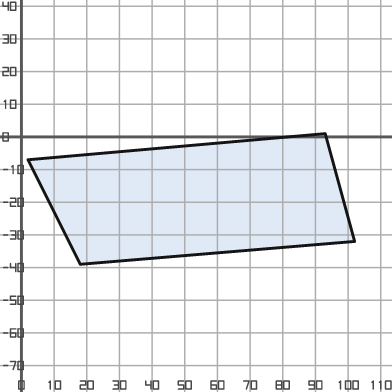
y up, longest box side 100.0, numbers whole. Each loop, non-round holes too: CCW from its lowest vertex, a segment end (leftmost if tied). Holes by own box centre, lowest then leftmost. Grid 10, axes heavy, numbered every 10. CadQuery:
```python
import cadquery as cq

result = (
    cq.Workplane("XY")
    .moveTo(18.0, -39.0)
    .lineTo(102.0, -32.0)
    .lineTo(93.0, 1.0)
    .lineTo(2.0, -7.0)
    .close()
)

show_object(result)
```